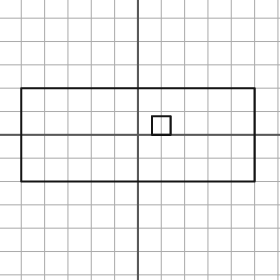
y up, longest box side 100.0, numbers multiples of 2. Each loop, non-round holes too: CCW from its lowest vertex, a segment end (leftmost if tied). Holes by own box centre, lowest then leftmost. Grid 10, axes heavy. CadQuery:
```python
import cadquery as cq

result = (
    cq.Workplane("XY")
    .moveTo(-50.0, -20.0)
    .lineTo(50.0, -20.0)
    .lineTo(50.0, 20.0)
    .lineTo(-50.0, 20.0)
    .close()
    .moveTo(6.0, 0.0)
    .lineTo(14.0, 0.0)
    .lineTo(14.0, 8.0)
    .lineTo(6.0, 8.0)
    .close()
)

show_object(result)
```